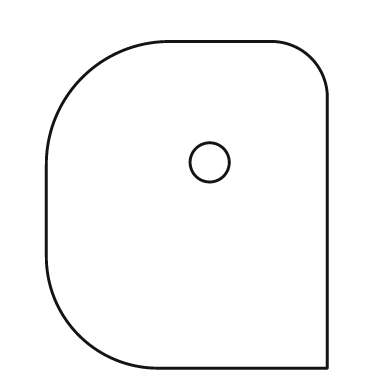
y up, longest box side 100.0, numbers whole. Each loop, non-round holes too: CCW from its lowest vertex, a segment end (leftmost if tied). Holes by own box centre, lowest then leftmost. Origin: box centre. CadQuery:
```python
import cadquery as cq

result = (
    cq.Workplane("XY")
    .moveTo(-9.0, -50.0)
    .lineTo(43.0, -50.0)
    .lineTo(43.0, 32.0)
    .threePointArc((38.0, 45.0), (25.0, 50.0))
    .lineTo(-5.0, 50.0)
    .threePointArc((-32.0, 39.0), (-43.0, 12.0))
    .lineTo(-43.0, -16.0)
    .threePointArc((-33.0, -40.0), (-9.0, -50.0))
    .close()
    .moveTo(7.0, 13.0)
    .circle(6.0)
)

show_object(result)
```